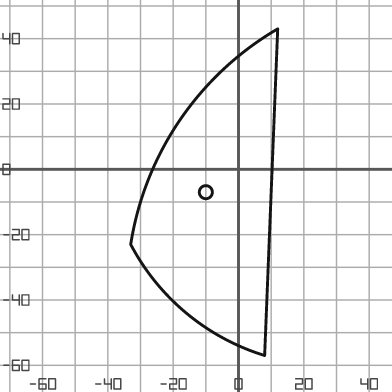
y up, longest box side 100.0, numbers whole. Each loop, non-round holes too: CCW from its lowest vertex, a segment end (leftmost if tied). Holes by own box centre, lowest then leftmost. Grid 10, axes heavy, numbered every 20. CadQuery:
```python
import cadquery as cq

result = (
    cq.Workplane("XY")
    .moveTo(8.0, -57.0)
    .lineTo(12.0, 43.0)
    .threePointArc((-18.0, 15.0), (-33.0, -23.0))
    .threePointArc((-16.0, -44.0), (8.0, -57.0))
    .close()
    .moveTo(-10.0, -7.0)
    .circle(2.0)
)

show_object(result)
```